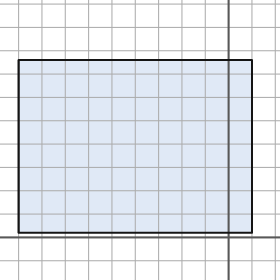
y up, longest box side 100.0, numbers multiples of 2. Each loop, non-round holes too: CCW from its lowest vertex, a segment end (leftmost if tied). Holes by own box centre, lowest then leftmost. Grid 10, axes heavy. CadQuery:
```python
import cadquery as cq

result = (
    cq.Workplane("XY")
    .moveTo(-90.0, 2.0)
    .lineTo(10.0, 2.0)
    .lineTo(10.0, 76.0)
    .lineTo(-90.0, 76.0)
    .close()
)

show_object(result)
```